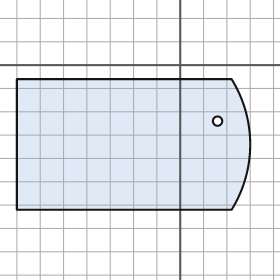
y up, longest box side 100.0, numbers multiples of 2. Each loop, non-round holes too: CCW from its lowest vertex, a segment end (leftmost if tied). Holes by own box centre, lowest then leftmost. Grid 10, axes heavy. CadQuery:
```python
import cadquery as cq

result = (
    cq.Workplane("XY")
    .moveTo(-70.0, -62.0)
    .lineTo(22.0, -62.0)
    .threePointArc((30.0, -34.0), (22.0, -6.0))
    .lineTo(-70.0, -6.0)
    .close()
    .moveTo(16.0, -24.0)
    .circle(2.0)
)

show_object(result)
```